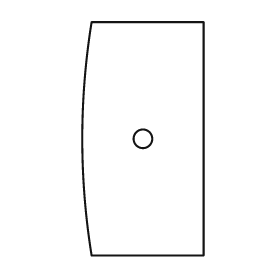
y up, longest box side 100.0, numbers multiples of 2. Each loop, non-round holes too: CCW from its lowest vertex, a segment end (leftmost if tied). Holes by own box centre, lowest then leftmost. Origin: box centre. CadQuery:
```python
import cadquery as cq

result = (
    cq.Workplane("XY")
    .moveTo(-22.0, -50.0)
    .lineTo(26.0, -50.0)
    .lineTo(26.0, 50.0)
    .lineTo(-22.0, 50.0)
    .threePointArc((-26.0, 0.0), (-22.0, -50.0))
    .close()
    .moveTo(0.0, 0.0)
    .circle(4.0)
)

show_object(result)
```